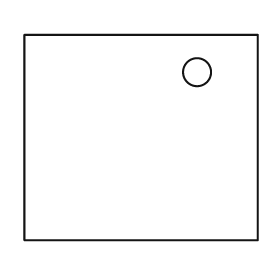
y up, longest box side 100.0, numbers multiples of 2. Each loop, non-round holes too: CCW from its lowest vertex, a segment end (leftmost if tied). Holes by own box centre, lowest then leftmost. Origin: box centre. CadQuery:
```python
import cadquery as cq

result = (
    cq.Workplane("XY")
    .moveTo(-50.0, -44.0)
    .lineTo(50.0, -44.0)
    .lineTo(50.0, 44.0)
    .lineTo(-50.0, 44.0)
    .close()
    .moveTo(24.0, 28.0)
    .circle(6.0)
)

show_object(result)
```